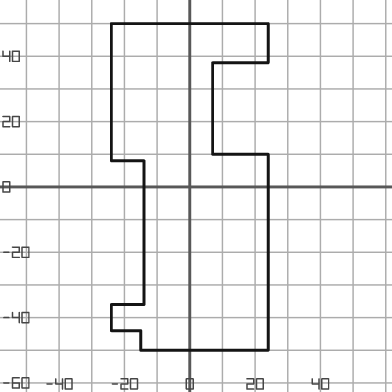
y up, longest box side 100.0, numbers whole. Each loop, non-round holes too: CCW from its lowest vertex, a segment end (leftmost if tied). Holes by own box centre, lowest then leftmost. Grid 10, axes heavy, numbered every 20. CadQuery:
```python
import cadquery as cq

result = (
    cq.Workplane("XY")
    .moveTo(-15.0, -50.0)
    .lineTo(24.0, -50.0)
    .lineTo(24.0, 10.0)
    .lineTo(7.0, 10.0)
    .lineTo(7.0, 38.0)
    .lineTo(24.0, 38.0)
    .lineTo(24.0, 50.0)
    .lineTo(-24.0, 50.0)
    .lineTo(-24.0, 8.0)
    .lineTo(-14.0, 8.0)
    .lineTo(-14.0, -36.0)
    .lineTo(-24.0, -36.0)
    .lineTo(-24.0, -44.0)
    .lineTo(-15.0, -44.0)
    .close()
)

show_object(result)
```